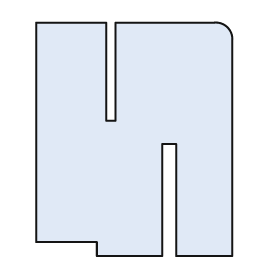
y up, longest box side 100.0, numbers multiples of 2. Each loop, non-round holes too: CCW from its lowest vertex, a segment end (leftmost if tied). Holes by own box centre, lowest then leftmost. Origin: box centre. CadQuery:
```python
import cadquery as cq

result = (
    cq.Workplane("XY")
    .moveTo(-16.0, -50.0)
    .lineTo(12.0, -50.0)
    .lineTo(12.0, -2.0)
    .lineTo(18.0, -2.0)
    .lineTo(18.0, -50.0)
    .lineTo(42.0, -50.0)
    .lineTo(42.0, 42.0)
    .threePointArc((40.0, 48.0), (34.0, 50.0))
    .lineTo(-8.0, 50.0)
    .lineTo(-8.0, 8.0)
    .lineTo(-12.0, 8.0)
    .lineTo(-12.0, 50.0)
    .lineTo(-42.0, 50.0)
    .lineTo(-42.0, -44.0)
    .lineTo(-16.0, -44.0)
    .close()
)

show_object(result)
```